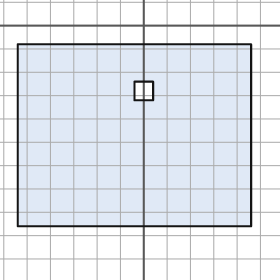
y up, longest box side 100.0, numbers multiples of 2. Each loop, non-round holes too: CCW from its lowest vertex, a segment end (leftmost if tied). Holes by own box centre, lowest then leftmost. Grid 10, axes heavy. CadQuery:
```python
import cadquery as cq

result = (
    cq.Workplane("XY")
    .moveTo(-54.0, -86.0)
    .lineTo(46.0, -86.0)
    .lineTo(46.0, -8.0)
    .lineTo(-54.0, -8.0)
    .close()
    .moveTo(-4.0, -32.0)
    .lineTo(4.0, -32.0)
    .lineTo(4.0, -24.0)
    .lineTo(-4.0, -24.0)
    .close()
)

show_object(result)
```